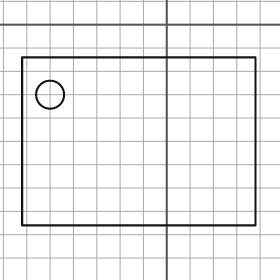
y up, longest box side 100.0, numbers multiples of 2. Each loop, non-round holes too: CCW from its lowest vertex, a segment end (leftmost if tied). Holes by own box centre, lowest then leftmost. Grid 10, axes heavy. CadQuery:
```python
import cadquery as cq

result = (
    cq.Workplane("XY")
    .moveTo(-62.0, -86.0)
    .lineTo(38.0, -86.0)
    .lineTo(38.0, -14.0)
    .lineTo(-62.0, -14.0)
    .close()
    .moveTo(-50.0, -30.0)
    .circle(6.0)
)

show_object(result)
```